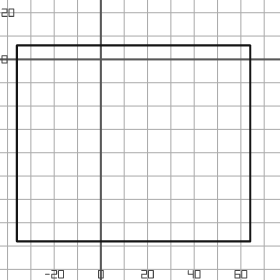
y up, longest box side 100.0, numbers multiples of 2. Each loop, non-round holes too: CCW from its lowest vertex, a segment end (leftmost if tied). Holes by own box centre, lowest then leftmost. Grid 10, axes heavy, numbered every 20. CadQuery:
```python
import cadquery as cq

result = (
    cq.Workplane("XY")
    .moveTo(-36.0, -78.0)
    .lineTo(64.0, -78.0)
    .lineTo(64.0, 6.0)
    .lineTo(-36.0, 6.0)
    .close()
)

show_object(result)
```